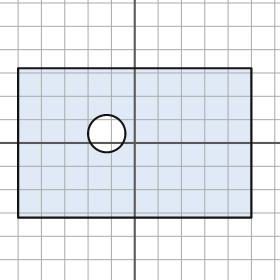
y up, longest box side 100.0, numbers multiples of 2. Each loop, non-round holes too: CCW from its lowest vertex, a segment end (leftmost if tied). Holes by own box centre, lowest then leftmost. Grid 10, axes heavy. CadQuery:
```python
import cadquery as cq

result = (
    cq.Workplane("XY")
    .moveTo(-50.0, -32.0)
    .lineTo(50.0, -32.0)
    .lineTo(50.0, 32.0)
    .lineTo(-50.0, 32.0)
    .close()
    .moveTo(-12.0, 4.0)
    .circle(8.0)
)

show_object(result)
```